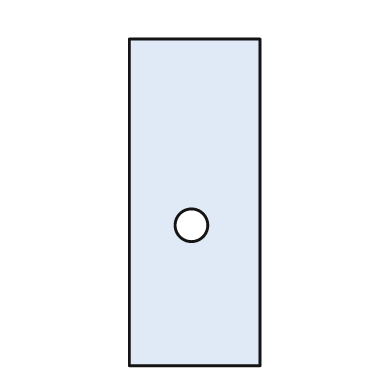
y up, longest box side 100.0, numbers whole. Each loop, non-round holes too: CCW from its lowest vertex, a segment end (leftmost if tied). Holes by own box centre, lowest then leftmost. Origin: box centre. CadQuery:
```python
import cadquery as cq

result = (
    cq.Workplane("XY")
    .moveTo(-20.0, -50.0)
    .lineTo(20.0, -50.0)
    .lineTo(20.0, 50.0)
    .lineTo(-20.0, 50.0)
    .close()
    .moveTo(-1.0, -7.0)
    .circle(5.0)
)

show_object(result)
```